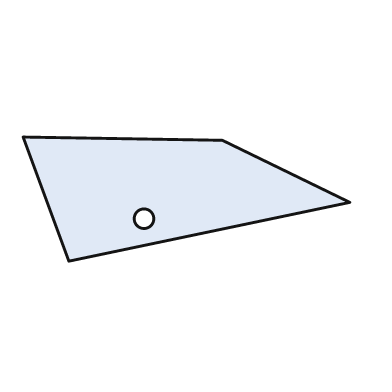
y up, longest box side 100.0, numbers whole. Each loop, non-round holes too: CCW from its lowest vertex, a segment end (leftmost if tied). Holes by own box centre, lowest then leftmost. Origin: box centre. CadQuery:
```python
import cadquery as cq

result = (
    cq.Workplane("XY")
    .moveTo(-36.0, -19.0)
    .lineTo(50.0, -1.0)
    .lineTo(11.0, 18.0)
    .lineTo(-50.0, 19.0)
    .close()
    .moveTo(-13.0, -6.0)
    .circle(3.0)
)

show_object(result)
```